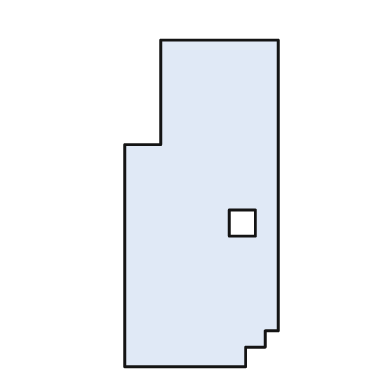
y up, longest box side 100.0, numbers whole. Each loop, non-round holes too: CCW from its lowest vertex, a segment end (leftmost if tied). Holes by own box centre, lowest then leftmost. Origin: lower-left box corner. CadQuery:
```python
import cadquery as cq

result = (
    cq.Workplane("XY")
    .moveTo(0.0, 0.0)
    .lineTo(37.0, 0.0)
    .lineTo(37.0, 6.0)
    .lineTo(43.0, 6.0)
    .lineTo(43.0, 11.0)
    .lineTo(47.0, 11.0)
    .lineTo(47.0, 100.0)
    .lineTo(11.0, 100.0)
    .lineTo(11.0, 68.0)
    .lineTo(0.0, 68.0)
    .close()
    .moveTo(32.0, 40.0)
    .lineTo(40.0, 40.0)
    .lineTo(40.0, 48.0)
    .lineTo(32.0, 48.0)
    .close()
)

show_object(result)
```